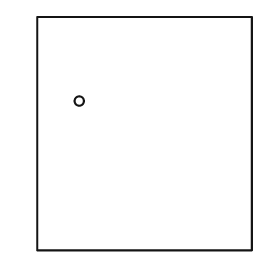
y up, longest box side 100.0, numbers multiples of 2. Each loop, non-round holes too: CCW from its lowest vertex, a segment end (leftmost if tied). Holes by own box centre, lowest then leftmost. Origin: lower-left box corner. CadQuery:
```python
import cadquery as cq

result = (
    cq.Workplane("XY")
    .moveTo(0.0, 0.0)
    .lineTo(92.0, 0.0)
    .lineTo(92.0, 100.0)
    .lineTo(0.0, 100.0)
    .close()
    .moveTo(18.0, 64.0)
    .circle(2.0)
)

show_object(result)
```